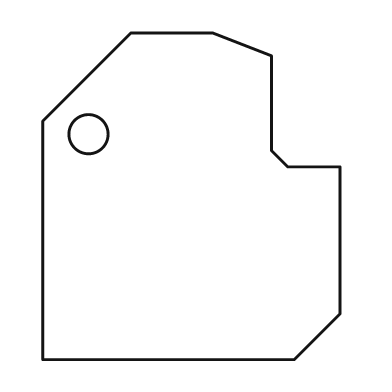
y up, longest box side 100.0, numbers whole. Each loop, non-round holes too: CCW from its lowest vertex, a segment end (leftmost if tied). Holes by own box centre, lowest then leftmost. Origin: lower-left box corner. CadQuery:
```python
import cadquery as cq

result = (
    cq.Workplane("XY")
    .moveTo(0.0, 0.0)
    .lineTo(77.0, 0.0)
    .lineTo(91.0, 14.0)
    .lineTo(91.0, 59.0)
    .lineTo(75.0, 59.0)
    .lineTo(70.0, 64.0)
    .lineTo(70.0, 93.0)
    .lineTo(52.0, 100.0)
    .lineTo(27.0, 100.0)
    .lineTo(0.0, 73.0)
    .close()
    .moveTo(14.0, 69.0)
    .circle(6.0)
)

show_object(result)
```